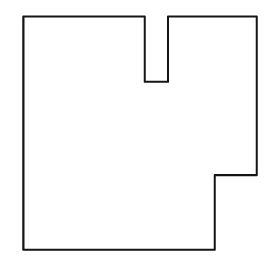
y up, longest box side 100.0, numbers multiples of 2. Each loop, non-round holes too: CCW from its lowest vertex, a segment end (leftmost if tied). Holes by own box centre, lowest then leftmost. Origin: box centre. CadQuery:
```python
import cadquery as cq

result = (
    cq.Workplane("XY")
    .moveTo(-50.0, -50.0)
    .lineTo(32.0, -50.0)
    .lineTo(32.0, -18.0)
    .lineTo(50.0, -18.0)
    .lineTo(50.0, 50.0)
    .lineTo(12.0, 50.0)
    .lineTo(12.0, 22.0)
    .lineTo(2.0, 22.0)
    .lineTo(2.0, 50.0)
    .lineTo(-50.0, 50.0)
    .close()
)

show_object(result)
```